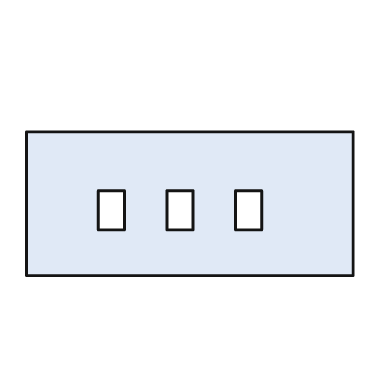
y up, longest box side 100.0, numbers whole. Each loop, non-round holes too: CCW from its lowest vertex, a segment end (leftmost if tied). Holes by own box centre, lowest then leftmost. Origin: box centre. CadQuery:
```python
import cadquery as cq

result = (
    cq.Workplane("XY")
    .moveTo(-50.0, -22.0)
    .lineTo(50.0, -22.0)
    .lineTo(50.0, 22.0)
    .lineTo(-50.0, 22.0)
    .close()
    .moveTo(-28.0, -8.0)
    .lineTo(-20.0, -8.0)
    .lineTo(-20.0, 4.0)
    .lineTo(-28.0, 4.0)
    .close()
    .moveTo(-7.0, -8.0)
    .lineTo(1.0, -8.0)
    .lineTo(1.0, 4.0)
    .lineTo(-7.0, 4.0)
    .close()
    .moveTo(14.0, -8.0)
    .lineTo(22.0, -8.0)
    .lineTo(22.0, 4.0)
    .lineTo(14.0, 4.0)
    .close()
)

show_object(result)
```